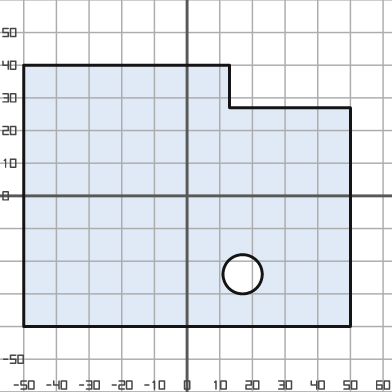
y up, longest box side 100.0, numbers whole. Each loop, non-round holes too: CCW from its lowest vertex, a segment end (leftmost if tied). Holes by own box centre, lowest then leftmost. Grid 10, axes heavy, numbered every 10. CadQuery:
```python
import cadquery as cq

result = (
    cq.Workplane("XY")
    .moveTo(-50.0, -40.0)
    .lineTo(50.0, -40.0)
    .lineTo(50.0, 27.0)
    .lineTo(13.0, 27.0)
    .lineTo(13.0, 40.0)
    .lineTo(-50.0, 40.0)
    .close()
    .moveTo(17.0, -24.0)
    .circle(6.0)
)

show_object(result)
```